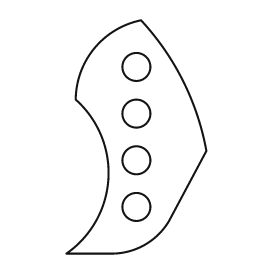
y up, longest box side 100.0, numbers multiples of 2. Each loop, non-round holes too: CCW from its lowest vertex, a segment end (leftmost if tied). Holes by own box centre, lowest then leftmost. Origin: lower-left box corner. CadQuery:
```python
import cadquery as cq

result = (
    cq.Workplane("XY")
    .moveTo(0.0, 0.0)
    .lineTo(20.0, 0.0)
    .threePointArc((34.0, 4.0), (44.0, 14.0))
    .lineTo(60.0, 44.0)
    .threePointArc((50.0, 74.0), (32.0, 100.0))
    .threePointArc((12.0, 88.0), (4.0, 66.0))
    .threePointArc((18.0, 32.0), (0.0, 0.0))
    .close()
    .moveTo(30.0, 20.0)
    .circle(6.0)
    .moveTo(30.0, 40.0)
    .circle(6.0)
    .moveTo(30.0, 60.0)
    .circle(6.0)
    .moveTo(30.0, 80.0)
    .circle(6.0)
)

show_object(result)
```